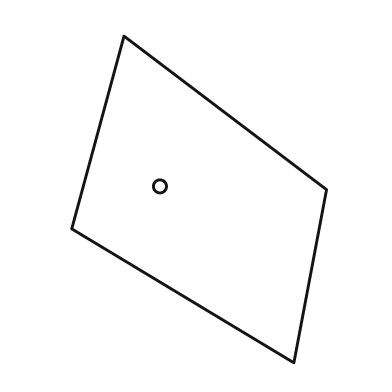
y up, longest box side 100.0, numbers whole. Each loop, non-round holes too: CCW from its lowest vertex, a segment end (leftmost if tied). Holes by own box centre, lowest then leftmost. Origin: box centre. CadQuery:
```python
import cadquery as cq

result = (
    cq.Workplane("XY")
    .moveTo(29.0, -50.0)
    .lineTo(39.0, 3.0)
    .lineTo(-23.0, 50.0)
    .lineTo(-39.0, -9.0)
    .close()
    .moveTo(-12.0, 4.0)
    .circle(2.0)
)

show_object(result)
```